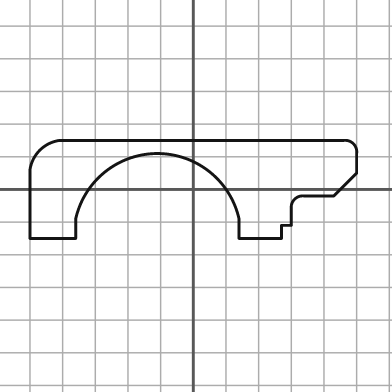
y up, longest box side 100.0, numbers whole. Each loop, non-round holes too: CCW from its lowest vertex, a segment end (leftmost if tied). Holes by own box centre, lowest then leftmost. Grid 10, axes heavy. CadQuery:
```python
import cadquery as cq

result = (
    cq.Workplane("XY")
    .moveTo(-50.0, -15.0)
    .lineTo(-36.0, -15.0)
    .lineTo(-36.0, -9.0)
    .threePointArc((-11.0, 11.0), (14.0, -9.0))
    .lineTo(14.0, -15.0)
    .lineTo(27.0, -15.0)
    .lineTo(27.0, -11.0)
    .lineTo(30.0, -11.0)
    .lineTo(30.0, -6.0)
    .threePointArc((31.0, -3.0), (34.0, -2.0))
    .lineTo(43.0, -2.0)
    .lineTo(50.0, 5.0)
    .lineTo(50.0, 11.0)
    .threePointArc((49.0, 14.0), (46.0, 15.0))
    .lineTo(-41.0, 15.0)
    .threePointArc((-47.0, 12.0), (-50.0, 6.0))
    .close()
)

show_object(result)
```